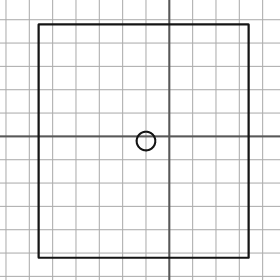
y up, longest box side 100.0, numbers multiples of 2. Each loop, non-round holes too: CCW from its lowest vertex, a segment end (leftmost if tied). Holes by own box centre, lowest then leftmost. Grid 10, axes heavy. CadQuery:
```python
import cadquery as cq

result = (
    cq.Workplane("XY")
    .moveTo(-56.0, -52.0)
    .lineTo(34.0, -52.0)
    .lineTo(34.0, 48.0)
    .lineTo(-56.0, 48.0)
    .close()
    .moveTo(-10.0, -2.0)
    .circle(4.0)
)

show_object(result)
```